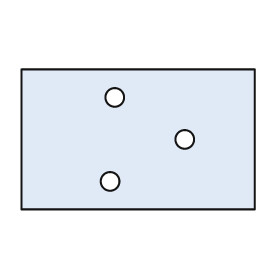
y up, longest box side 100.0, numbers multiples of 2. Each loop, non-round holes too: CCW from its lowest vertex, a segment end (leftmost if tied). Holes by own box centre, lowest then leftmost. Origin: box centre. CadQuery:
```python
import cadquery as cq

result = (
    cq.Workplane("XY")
    .moveTo(-50.0, -30.0)
    .lineTo(50.0, -30.0)
    .lineTo(50.0, 30.0)
    .lineTo(-50.0, 30.0)
    .close()
    .moveTo(-12.0, -18.0)
    .circle(4.0)
    .moveTo(20.0, 0.0)
    .circle(4.0)
    .moveTo(-10.0, 18.0)
    .circle(4.0)
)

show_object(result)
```